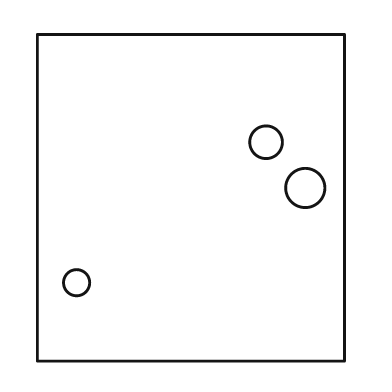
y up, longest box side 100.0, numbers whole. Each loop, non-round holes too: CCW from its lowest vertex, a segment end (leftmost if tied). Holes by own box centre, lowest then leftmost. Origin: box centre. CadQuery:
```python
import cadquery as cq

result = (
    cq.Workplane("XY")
    .moveTo(-47.0, -50.0)
    .lineTo(47.0, -50.0)
    .lineTo(47.0, 50.0)
    .lineTo(-47.0, 50.0)
    .close()
    .moveTo(-35.0, -26.0)
    .circle(4.0)
    .moveTo(35.0, 3.0)
    .circle(6.0)
    .moveTo(23.0, 17.0)
    .circle(5.0)
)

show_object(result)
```